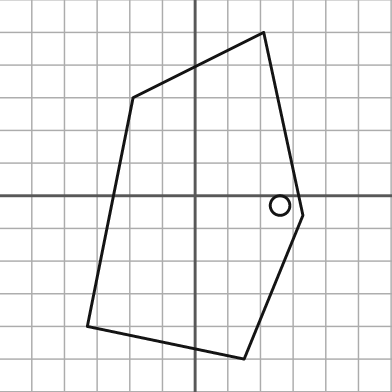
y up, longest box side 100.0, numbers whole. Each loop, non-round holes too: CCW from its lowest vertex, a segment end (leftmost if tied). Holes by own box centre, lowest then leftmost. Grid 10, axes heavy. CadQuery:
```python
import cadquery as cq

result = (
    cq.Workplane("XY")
    .moveTo(15.0, -50.0)
    .lineTo(33.0, -6.0)
    .lineTo(21.0, 50.0)
    .lineTo(-19.0, 30.0)
    .lineTo(-33.0, -40.0)
    .close()
    .moveTo(26.0, -3.0)
    .circle(3.0)
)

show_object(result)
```